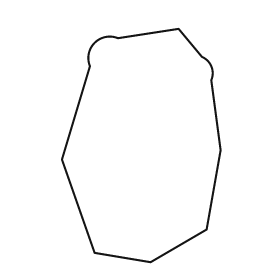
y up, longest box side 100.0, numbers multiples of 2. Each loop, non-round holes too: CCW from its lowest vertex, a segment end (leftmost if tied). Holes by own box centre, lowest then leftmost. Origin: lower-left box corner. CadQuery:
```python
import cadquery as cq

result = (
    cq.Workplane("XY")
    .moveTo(38.0, 0.0)
    .lineTo(62.0, 14.0)
    .lineTo(68.0, 48.0)
    .lineTo(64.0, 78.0)
    .threePointArc((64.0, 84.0), (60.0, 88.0))
    .lineTo(50.0, 100.0)
    .lineTo(24.0, 96.0)
    .threePointArc((14.0, 94.0), (12.0, 84.0))
    .lineTo(0.0, 44.0)
    .lineTo(14.0, 4.0)
    .close()
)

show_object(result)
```